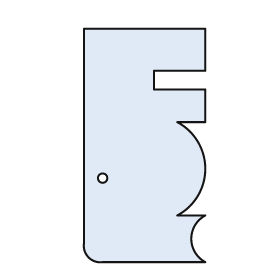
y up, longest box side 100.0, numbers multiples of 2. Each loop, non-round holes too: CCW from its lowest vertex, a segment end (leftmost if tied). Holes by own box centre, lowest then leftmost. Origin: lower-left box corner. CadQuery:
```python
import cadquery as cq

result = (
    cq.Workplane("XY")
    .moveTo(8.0, 0.0)
    .lineTo(52.0, 0.0)
    .threePointArc((46.0, 10.0), (52.0, 20.0))
    .lineTo(40.0, 20.0)
    .threePointArc((52.0, 40.0), (40.0, 60.0))
    .lineTo(52.0, 60.0)
    .lineTo(52.0, 74.0)
    .lineTo(30.0, 74.0)
    .lineTo(30.0, 82.0)
    .lineTo(52.0, 82.0)
    .lineTo(52.0, 100.0)
    .lineTo(0.0, 100.0)
    .lineTo(0.0, 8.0)
    .threePointArc((2.0, 2.0), (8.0, 0.0))
    .close()
    .moveTo(8.0, 36.0)
    .circle(2.0)
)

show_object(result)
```